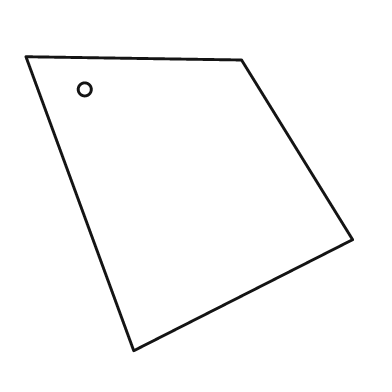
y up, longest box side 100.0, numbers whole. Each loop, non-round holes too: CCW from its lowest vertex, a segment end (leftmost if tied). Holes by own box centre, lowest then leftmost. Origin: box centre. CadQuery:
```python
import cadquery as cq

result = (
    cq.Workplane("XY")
    .moveTo(-17.0, -45.0)
    .lineTo(50.0, -11.0)
    .lineTo(16.0, 44.0)
    .lineTo(-50.0, 45.0)
    .close()
    .moveTo(-32.0, 35.0)
    .circle(2.0)
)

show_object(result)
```